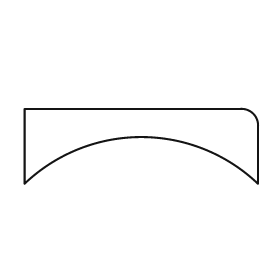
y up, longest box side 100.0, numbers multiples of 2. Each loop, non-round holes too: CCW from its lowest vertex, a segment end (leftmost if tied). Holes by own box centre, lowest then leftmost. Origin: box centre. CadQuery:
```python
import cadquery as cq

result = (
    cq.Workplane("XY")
    .moveTo(-50.0, -16.0)
    .threePointArc((0.0, 4.0), (50.0, -16.0))
    .lineTo(50.0, 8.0)
    .threePointArc((48.0, 14.0), (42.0, 16.0))
    .lineTo(-50.0, 16.0)
    .close()
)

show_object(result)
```